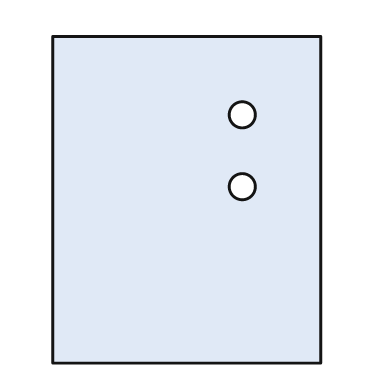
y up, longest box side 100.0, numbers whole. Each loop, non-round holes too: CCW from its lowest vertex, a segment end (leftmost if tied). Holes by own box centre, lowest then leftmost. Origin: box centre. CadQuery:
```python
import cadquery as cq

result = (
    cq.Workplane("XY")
    .moveTo(-41.0, -50.0)
    .lineTo(41.0, -50.0)
    .lineTo(41.0, 50.0)
    .lineTo(-41.0, 50.0)
    .close()
    .moveTo(17.0, 4.0)
    .circle(4.0)
    .moveTo(17.0, 26.0)
    .circle(4.0)
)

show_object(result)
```